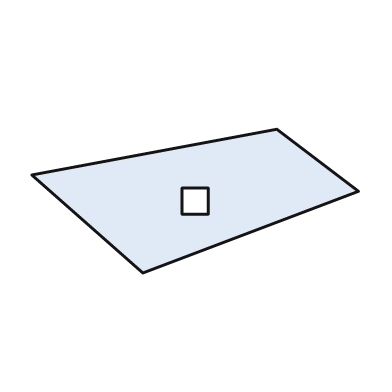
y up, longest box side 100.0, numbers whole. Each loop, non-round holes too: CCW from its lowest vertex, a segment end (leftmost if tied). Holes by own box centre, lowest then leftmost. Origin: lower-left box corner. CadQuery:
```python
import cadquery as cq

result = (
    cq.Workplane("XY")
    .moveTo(34.0, 0.0)
    .lineTo(100.0, 25.0)
    .lineTo(75.0, 44.0)
    .lineTo(0.0, 30.0)
    .close()
    .moveTo(46.0, 18.0)
    .lineTo(54.0, 18.0)
    .lineTo(54.0, 26.0)
    .lineTo(46.0, 26.0)
    .close()
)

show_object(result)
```